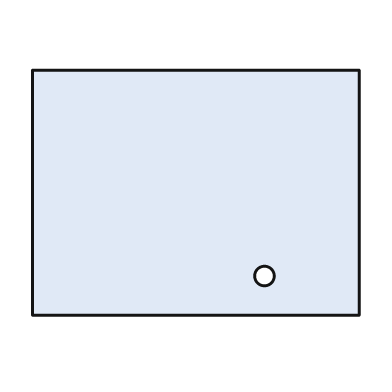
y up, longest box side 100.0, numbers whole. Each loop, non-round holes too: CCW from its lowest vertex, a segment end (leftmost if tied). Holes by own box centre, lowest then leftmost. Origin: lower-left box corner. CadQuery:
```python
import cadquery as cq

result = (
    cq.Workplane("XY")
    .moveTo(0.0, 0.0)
    .lineTo(100.0, 0.0)
    .lineTo(100.0, 75.0)
    .lineTo(0.0, 75.0)
    .close()
    .moveTo(71.0, 12.0)
    .circle(3.0)
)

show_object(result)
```